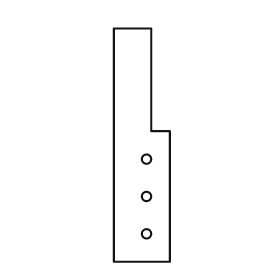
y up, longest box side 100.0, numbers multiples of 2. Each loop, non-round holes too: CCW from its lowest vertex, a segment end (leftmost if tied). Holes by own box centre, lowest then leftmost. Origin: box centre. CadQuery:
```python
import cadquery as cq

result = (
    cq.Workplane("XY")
    .moveTo(-12.0, -50.0)
    .lineTo(12.0, -50.0)
    .lineTo(12.0, 6.0)
    .lineTo(4.0, 6.0)
    .lineTo(4.0, 50.0)
    .lineTo(-12.0, 50.0)
    .close()
    .moveTo(2.0, -38.0)
    .circle(2.0)
    .moveTo(2.0, -22.0)
    .circle(2.0)
    .moveTo(2.0, -6.0)
    .circle(2.0)
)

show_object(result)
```